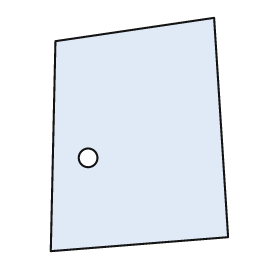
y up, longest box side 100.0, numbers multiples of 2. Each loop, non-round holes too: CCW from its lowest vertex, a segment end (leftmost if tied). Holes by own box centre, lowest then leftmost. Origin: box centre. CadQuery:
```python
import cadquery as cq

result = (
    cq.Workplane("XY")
    .moveTo(-38.0, -50.0)
    .lineTo(38.0, -44.0)
    .lineTo(32.0, 50.0)
    .lineTo(-36.0, 40.0)
    .close()
    .moveTo(-22.0, -10.0)
    .circle(4.0)
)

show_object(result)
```